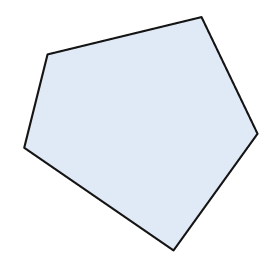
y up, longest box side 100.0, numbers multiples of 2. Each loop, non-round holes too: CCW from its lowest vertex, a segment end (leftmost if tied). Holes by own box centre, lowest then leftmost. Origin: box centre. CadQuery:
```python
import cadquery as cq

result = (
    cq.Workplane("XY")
    .moveTo(14.0, -50.0)
    .lineTo(50.0, 0.0)
    .lineTo(26.0, 50.0)
    .lineTo(-40.0, 34.0)
    .lineTo(-50.0, -6.0)
    .close()
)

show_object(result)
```